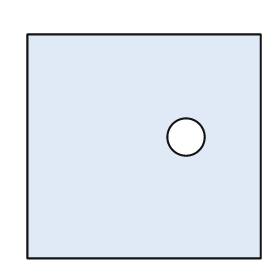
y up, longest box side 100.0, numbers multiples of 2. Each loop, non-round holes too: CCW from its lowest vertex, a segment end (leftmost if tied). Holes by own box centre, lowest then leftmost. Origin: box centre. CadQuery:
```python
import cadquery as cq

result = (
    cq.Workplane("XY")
    .moveTo(-50.0, -48.0)
    .lineTo(50.0, -48.0)
    .lineTo(50.0, 48.0)
    .lineTo(-50.0, 48.0)
    .close()
    .moveTo(18.0, 4.0)
    .circle(8.0)
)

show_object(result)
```